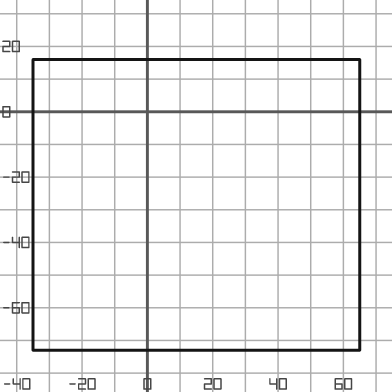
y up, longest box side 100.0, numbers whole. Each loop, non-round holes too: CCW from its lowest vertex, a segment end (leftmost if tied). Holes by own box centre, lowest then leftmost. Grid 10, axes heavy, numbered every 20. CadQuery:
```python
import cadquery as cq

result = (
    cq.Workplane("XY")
    .moveTo(-35.0, -73.0)
    .lineTo(65.0, -73.0)
    .lineTo(65.0, 16.0)
    .lineTo(-35.0, 16.0)
    .close()
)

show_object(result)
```